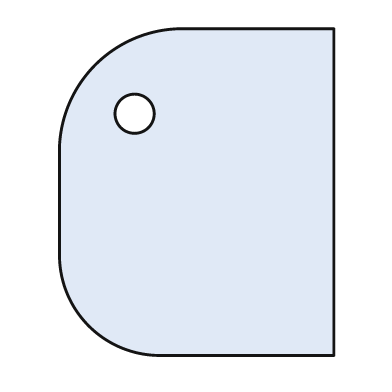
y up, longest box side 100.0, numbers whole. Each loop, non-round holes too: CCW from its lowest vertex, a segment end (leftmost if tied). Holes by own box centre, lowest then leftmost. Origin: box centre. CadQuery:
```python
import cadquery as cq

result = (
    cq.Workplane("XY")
    .moveTo(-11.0, -50.0)
    .lineTo(42.0, -50.0)
    .lineTo(42.0, 50.0)
    .lineTo(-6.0, 50.0)
    .threePointArc((-31.0, 39.0), (-42.0, 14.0))
    .lineTo(-42.0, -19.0)
    .threePointArc((-33.0, -41.0), (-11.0, -50.0))
    .close()
    .moveTo(-19.0, 24.0)
    .circle(6.0)
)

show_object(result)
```